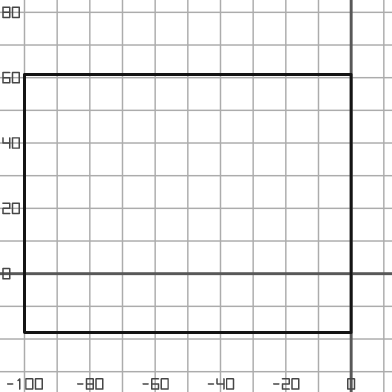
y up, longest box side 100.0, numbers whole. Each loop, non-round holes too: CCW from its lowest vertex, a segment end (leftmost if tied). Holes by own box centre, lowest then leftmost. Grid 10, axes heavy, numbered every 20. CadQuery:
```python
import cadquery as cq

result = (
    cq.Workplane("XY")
    .moveTo(-100.0, -18.0)
    .lineTo(0.0, -18.0)
    .lineTo(0.0, 61.0)
    .lineTo(-100.0, 61.0)
    .close()
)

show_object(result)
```